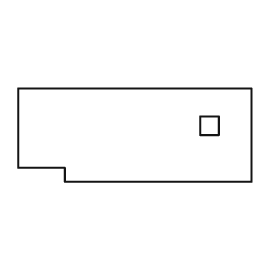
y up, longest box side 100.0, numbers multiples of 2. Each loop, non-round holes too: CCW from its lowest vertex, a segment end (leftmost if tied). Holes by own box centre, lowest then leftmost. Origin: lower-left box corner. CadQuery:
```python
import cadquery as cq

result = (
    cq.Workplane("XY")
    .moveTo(20.0, 0.0)
    .lineTo(100.0, 0.0)
    .lineTo(100.0, 40.0)
    .lineTo(0.0, 40.0)
    .lineTo(0.0, 6.0)
    .lineTo(20.0, 6.0)
    .close()
    .moveTo(78.0, 20.0)
    .lineTo(86.0, 20.0)
    .lineTo(86.0, 28.0)
    .lineTo(78.0, 28.0)
    .close()
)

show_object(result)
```